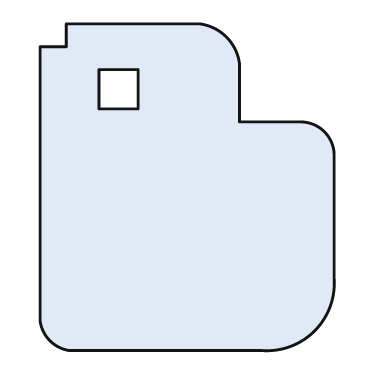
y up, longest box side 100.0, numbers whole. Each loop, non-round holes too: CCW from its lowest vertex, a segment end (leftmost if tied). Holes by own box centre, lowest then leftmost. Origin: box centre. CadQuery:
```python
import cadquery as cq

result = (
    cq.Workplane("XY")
    .moveTo(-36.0, -50.0)
    .lineTo(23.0, -50.0)
    .threePointArc((39.0, -44.0), (45.0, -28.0))
    .lineTo(45.0, 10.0)
    .threePointArc((42.0, 17.0), (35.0, 20.0))
    .lineTo(16.0, 20.0)
    .lineTo(16.0, 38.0)
    .threePointArc((12.0, 46.0), (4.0, 50.0))
    .lineTo(-37.0, 50.0)
    .lineTo(-37.0, 43.0)
    .lineTo(-45.0, 43.0)
    .lineTo(-45.0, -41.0)
    .threePointArc((-42.0, -47.0), (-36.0, -50.0))
    .close()
    .moveTo(-27.0, 24.0)
    .lineTo(-15.0, 24.0)
    .lineTo(-15.0, 36.0)
    .lineTo(-27.0, 36.0)
    .close()
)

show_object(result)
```